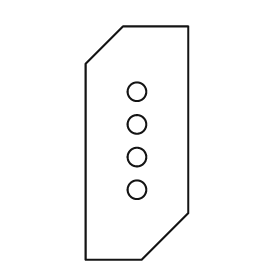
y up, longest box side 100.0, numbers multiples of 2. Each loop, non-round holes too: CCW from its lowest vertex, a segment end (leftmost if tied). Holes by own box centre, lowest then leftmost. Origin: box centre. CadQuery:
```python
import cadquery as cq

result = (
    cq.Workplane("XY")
    .moveTo(-22.0, -50.0)
    .lineTo(2.0, -50.0)
    .lineTo(22.0, -30.0)
    .lineTo(22.0, 50.0)
    .lineTo(-6.0, 50.0)
    .lineTo(-22.0, 34.0)
    .close()
    .moveTo(0.0, -20.0)
    .circle(4.0)
    .moveTo(0.0, -6.0)
    .circle(4.0)
    .moveTo(0.0, 8.0)
    .circle(4.0)
    .moveTo(0.0, 22.0)
    .circle(4.0)
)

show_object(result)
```